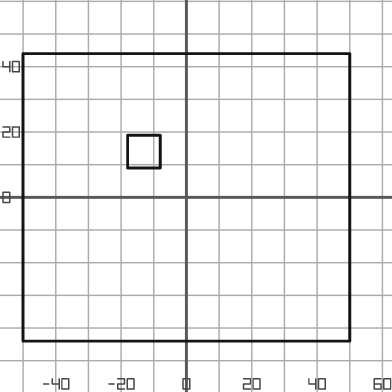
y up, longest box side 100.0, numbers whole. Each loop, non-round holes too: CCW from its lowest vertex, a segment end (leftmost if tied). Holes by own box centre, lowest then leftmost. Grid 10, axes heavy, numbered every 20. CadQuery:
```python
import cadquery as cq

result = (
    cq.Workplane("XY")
    .moveTo(-50.0, -44.0)
    .lineTo(50.0, -44.0)
    .lineTo(50.0, 44.0)
    .lineTo(-50.0, 44.0)
    .close()
    .moveTo(-18.0, 9.0)
    .lineTo(-8.0, 9.0)
    .lineTo(-8.0, 19.0)
    .lineTo(-18.0, 19.0)
    .close()
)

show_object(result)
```